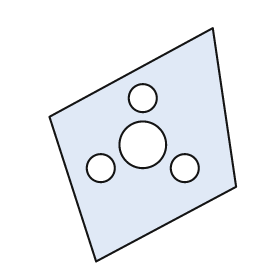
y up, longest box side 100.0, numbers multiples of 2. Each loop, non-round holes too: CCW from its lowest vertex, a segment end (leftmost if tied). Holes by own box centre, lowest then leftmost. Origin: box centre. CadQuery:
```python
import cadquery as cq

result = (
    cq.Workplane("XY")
    .moveTo(-20.0, -50.0)
    .lineTo(40.0, -18.0)
    .lineTo(30.0, 50.0)
    .lineTo(-40.0, 12.0)
    .close()
    .moveTo(-18.0, -10.0)
    .circle(6.0)
    .moveTo(18.0, -10.0)
    .circle(6.0)
    .moveTo(0.0, 0.0)
    .circle(10.0)
    .moveTo(0.0, 20.0)
    .circle(6.0)
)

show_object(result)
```